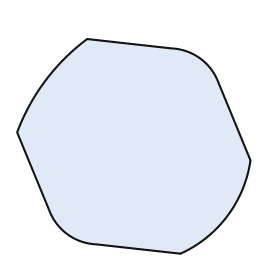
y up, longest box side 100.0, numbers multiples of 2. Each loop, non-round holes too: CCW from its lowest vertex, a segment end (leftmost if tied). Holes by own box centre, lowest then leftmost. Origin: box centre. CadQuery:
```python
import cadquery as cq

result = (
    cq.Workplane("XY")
    .moveTo(20.0, -46.0)
    .threePointArc((40.0, -30.0), (50.0, -6.0))
    .lineTo(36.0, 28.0)
    .threePointArc((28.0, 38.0), (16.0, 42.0))
    .lineTo(-20.0, 46.0)
    .threePointArc((-38.0, 28.0), (-50.0, 6.0))
    .lineTo(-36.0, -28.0)
    .threePointArc((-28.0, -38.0), (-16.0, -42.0))
    .close()
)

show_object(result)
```